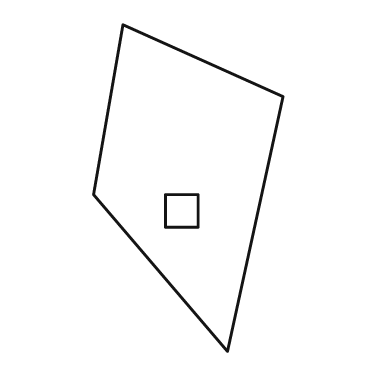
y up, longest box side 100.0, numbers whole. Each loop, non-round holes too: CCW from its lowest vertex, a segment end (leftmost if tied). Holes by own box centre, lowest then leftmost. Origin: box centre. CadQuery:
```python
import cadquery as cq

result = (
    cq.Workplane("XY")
    .moveTo(12.0, -50.0)
    .lineTo(29.0, 28.0)
    .lineTo(-20.0, 50.0)
    .lineTo(-29.0, -2.0)
    .close()
    .moveTo(-7.0, -12.0)
    .lineTo(3.0, -12.0)
    .lineTo(3.0, -2.0)
    .lineTo(-7.0, -2.0)
    .close()
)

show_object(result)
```